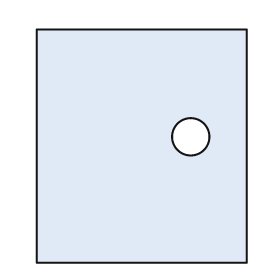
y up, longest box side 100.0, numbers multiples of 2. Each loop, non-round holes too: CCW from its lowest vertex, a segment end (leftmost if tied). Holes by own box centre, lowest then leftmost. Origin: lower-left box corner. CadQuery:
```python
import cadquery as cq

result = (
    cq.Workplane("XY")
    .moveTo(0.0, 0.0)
    .lineTo(90.0, 0.0)
    .lineTo(90.0, 100.0)
    .lineTo(0.0, 100.0)
    .close()
    .moveTo(66.0, 54.0)
    .circle(8.0)
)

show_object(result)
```